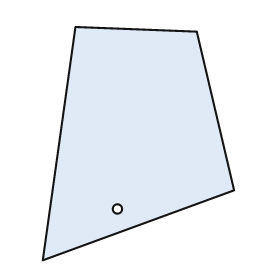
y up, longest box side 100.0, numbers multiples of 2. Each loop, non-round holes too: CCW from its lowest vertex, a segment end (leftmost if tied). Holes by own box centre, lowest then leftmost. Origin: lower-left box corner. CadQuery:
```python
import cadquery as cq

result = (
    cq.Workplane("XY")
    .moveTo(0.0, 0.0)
    .lineTo(82.0, 30.0)
    .lineTo(66.0, 98.0)
    .lineTo(14.0, 100.0)
    .close()
    .moveTo(32.0, 22.0)
    .circle(2.0)
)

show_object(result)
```